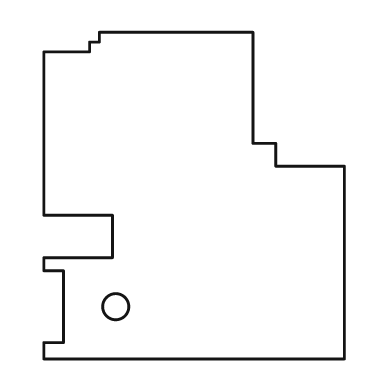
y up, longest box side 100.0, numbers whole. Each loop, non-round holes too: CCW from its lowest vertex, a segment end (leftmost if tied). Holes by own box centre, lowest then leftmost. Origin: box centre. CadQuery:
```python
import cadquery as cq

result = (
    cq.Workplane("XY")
    .moveTo(-46.0, -50.0)
    .lineTo(46.0, -50.0)
    .lineTo(46.0, 9.0)
    .lineTo(25.0, 9.0)
    .lineTo(25.0, 16.0)
    .lineTo(18.0, 16.0)
    .lineTo(18.0, 50.0)
    .lineTo(-29.0, 50.0)
    .lineTo(-29.0, 47.0)
    .lineTo(-32.0, 47.0)
    .lineTo(-32.0, 44.0)
    .lineTo(-46.0, 44.0)
    .lineTo(-46.0, -6.0)
    .lineTo(-25.0, -6.0)
    .lineTo(-25.0, -19.0)
    .lineTo(-46.0, -19.0)
    .lineTo(-46.0, -23.0)
    .lineTo(-40.0, -23.0)
    .lineTo(-40.0, -45.0)
    .lineTo(-46.0, -45.0)
    .close()
    .moveTo(-24.0, -34.0)
    .circle(4.0)
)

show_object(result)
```